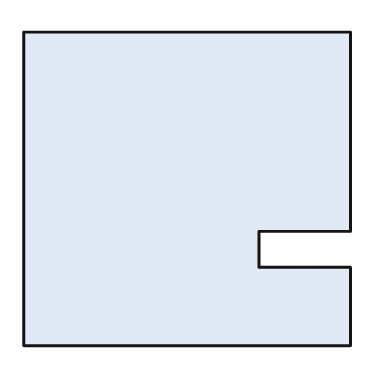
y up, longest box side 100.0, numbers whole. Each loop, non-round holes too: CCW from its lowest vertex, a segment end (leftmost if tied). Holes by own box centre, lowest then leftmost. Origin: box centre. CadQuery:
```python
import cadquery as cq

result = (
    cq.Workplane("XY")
    .moveTo(-50.0, -48.0)
    .lineTo(50.0, -48.0)
    .lineTo(50.0, -24.0)
    .lineTo(22.0, -24.0)
    .lineTo(22.0, -13.0)
    .lineTo(50.0, -13.0)
    .lineTo(50.0, 48.0)
    .lineTo(-50.0, 48.0)
    .close()
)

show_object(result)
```